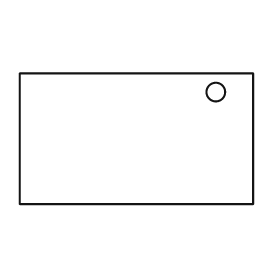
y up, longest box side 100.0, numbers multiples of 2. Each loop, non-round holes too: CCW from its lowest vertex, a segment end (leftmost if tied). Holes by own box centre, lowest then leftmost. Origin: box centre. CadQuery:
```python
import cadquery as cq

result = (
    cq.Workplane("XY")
    .moveTo(-50.0, -28.0)
    .lineTo(50.0, -28.0)
    .lineTo(50.0, 28.0)
    .lineTo(-50.0, 28.0)
    .close()
    .moveTo(34.0, 20.0)
    .circle(4.0)
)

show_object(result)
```